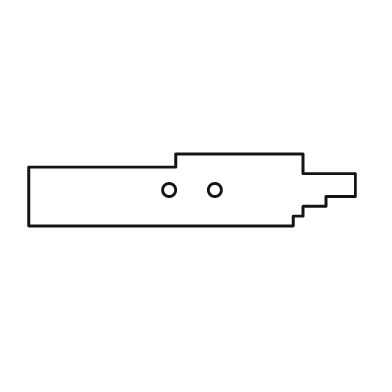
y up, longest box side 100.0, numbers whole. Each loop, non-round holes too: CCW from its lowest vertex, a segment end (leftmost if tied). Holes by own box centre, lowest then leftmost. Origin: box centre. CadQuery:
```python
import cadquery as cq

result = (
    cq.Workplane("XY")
    .moveTo(-50.0, -11.0)
    .lineTo(31.0, -11.0)
    .lineTo(31.0, -8.0)
    .lineTo(34.0, -8.0)
    .lineTo(34.0, -5.0)
    .lineTo(41.0, -5.0)
    .lineTo(41.0, -2.0)
    .lineTo(50.0, -2.0)
    .lineTo(50.0, 5.0)
    .lineTo(34.0, 5.0)
    .lineTo(34.0, 11.0)
    .lineTo(-5.0, 11.0)
    .lineTo(-5.0, 7.0)
    .lineTo(-50.0, 7.0)
    .close()
    .moveTo(-7.0, 0.0)
    .circle(2.0)
    .moveTo(7.0, 0.0)
    .circle(2.0)
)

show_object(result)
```